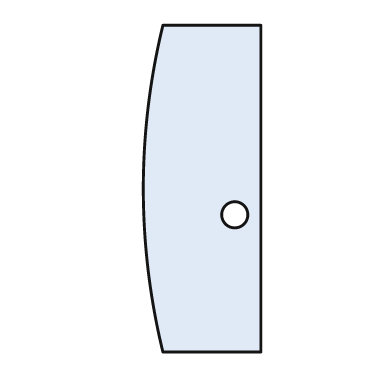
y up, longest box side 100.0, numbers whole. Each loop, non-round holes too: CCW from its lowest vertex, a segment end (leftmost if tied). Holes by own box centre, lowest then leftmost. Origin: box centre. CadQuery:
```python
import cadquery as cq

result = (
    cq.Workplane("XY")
    .moveTo(-12.0, -50.0)
    .lineTo(18.0, -50.0)
    .lineTo(18.0, 50.0)
    .lineTo(-12.0, 50.0)
    .threePointArc((-18.0, 0.0), (-12.0, -50.0))
    .close()
    .moveTo(10.0, -8.0)
    .circle(4.0)
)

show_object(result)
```